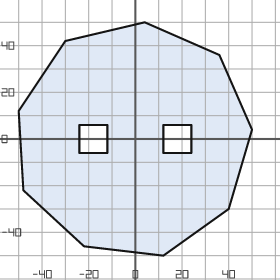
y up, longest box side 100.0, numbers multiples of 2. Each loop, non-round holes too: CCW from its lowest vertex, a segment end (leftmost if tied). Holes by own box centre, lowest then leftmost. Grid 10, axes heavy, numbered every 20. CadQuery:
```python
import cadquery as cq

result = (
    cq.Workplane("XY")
    .moveTo(12.0, -50.0)
    .lineTo(40.0, -30.0)
    .lineTo(50.0, 4.0)
    .lineTo(36.0, 36.0)
    .lineTo(4.0, 50.0)
    .lineTo(-30.0, 42.0)
    .lineTo(-50.0, 12.0)
    .lineTo(-48.0, -22.0)
    .lineTo(-22.0, -46.0)
    .close()
    .moveTo(-24.0, -6.0)
    .lineTo(-12.0, -6.0)
    .lineTo(-12.0, 6.0)
    .lineTo(-24.0, 6.0)
    .close()
    .moveTo(12.0, -6.0)
    .lineTo(24.0, -6.0)
    .lineTo(24.0, 6.0)
    .lineTo(12.0, 6.0)
    .close()
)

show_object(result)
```